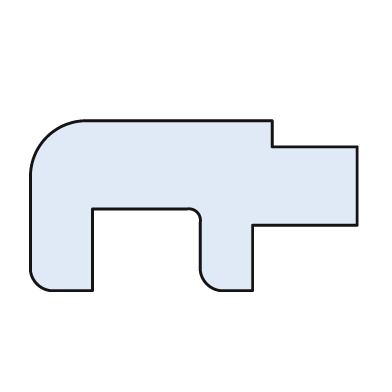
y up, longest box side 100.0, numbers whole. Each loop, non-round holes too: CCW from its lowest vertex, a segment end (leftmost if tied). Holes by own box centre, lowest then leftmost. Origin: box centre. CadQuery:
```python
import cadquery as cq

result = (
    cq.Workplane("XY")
    .moveTo(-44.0, -26.0)
    .lineTo(-31.0, -26.0)
    .lineTo(-31.0, -1.0)
    .lineTo(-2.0, -1.0)
    .threePointArc((1.0, -2.0), (2.0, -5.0))
    .lineTo(2.0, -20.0)
    .threePointArc((4.0, -24.0), (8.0, -26.0))
    .lineTo(18.0, -26.0)
    .lineTo(18.0, -6.0)
    .lineTo(50.0, -6.0)
    .lineTo(50.0, 18.0)
    .lineTo(24.0, 18.0)
    .lineTo(24.0, 26.0)
    .lineTo(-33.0, 26.0)
    .threePointArc((-45.0, 21.0), (-50.0, 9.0))
    .lineTo(-50.0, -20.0)
    .threePointArc((-48.0, -24.0), (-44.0, -26.0))
    .close()
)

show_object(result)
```